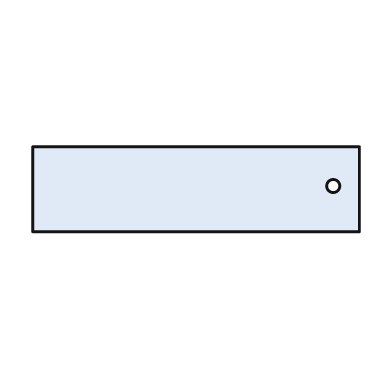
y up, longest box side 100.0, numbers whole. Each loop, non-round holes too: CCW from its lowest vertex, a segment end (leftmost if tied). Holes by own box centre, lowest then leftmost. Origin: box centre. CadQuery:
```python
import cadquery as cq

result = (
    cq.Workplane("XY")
    .moveTo(-50.0, -13.0)
    .lineTo(50.0, -13.0)
    .lineTo(50.0, 13.0)
    .lineTo(-50.0, 13.0)
    .close()
    .moveTo(42.0, 1.0)
    .circle(2.0)
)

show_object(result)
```